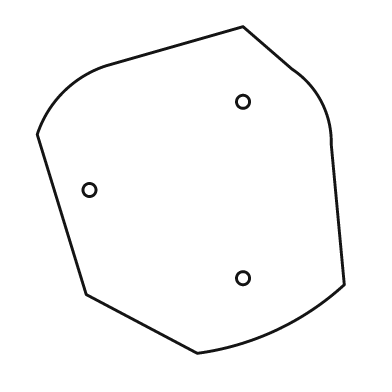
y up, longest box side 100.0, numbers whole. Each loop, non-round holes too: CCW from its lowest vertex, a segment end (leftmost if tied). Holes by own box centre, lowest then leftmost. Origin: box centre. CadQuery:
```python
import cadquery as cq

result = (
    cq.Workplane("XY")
    .moveTo(2.0, -50.0)
    .threePointArc((26.0, -43.0), (47.0, -29.0))
    .lineTo(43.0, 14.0)
    .threePointArc((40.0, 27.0), (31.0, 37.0))
    .lineTo(16.0, 50.0)
    .lineTo(-26.0, 38.0)
    .threePointArc((-39.0, 30.0), (-47.0, 17.0))
    .lineTo(-32.0, -32.0)
    .close()
    .moveTo(16.0, -27.0)
    .circle(2.0)
    .moveTo(-31.0, 0.0)
    .circle(2.0)
    .moveTo(16.0, 27.0)
    .circle(2.0)
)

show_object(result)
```